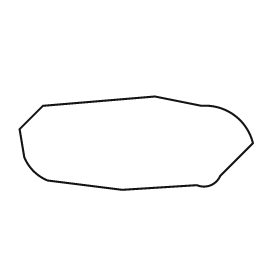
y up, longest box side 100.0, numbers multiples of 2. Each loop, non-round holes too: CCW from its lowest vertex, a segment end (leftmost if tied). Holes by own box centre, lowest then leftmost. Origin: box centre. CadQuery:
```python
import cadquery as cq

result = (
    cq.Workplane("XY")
    .moveTo(-6.0, -20.0)
    .lineTo(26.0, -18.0)
    .threePointArc((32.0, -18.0), (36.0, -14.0))
    .lineTo(50.0, 0.0)
    .threePointArc((42.0, 12.0), (28.0, 16.0))
    .lineTo(8.0, 20.0)
    .lineTo(-40.0, 16.0)
    .lineTo(-50.0, 6.0)
    .lineTo(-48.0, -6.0)
    .threePointArc((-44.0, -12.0), (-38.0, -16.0))
    .close()
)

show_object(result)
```